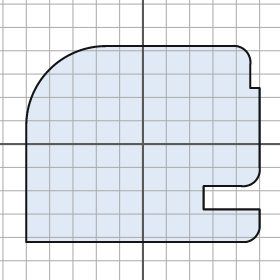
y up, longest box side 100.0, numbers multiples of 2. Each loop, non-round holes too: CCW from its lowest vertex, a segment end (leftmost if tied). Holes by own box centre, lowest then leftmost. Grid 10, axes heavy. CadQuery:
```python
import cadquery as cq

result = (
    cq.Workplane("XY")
    .moveTo(-50.0, -42.0)
    .lineTo(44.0, -42.0)
    .threePointArc((48.0, -40.0), (50.0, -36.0))
    .lineTo(50.0, -28.0)
    .lineTo(26.0, -28.0)
    .lineTo(26.0, -18.0)
    .lineTo(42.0, -18.0)
    .threePointArc((48.0, -16.0), (50.0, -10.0))
    .lineTo(50.0, 24.0)
    .lineTo(46.0, 24.0)
    .lineTo(46.0, 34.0)
    .threePointArc((44.0, 40.0), (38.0, 42.0))
    .lineTo(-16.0, 42.0)
    .threePointArc((-40.0, 32.0), (-50.0, 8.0))
    .close()
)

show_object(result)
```